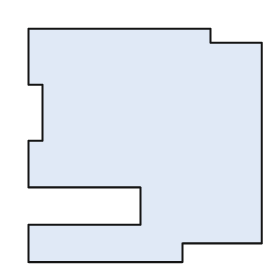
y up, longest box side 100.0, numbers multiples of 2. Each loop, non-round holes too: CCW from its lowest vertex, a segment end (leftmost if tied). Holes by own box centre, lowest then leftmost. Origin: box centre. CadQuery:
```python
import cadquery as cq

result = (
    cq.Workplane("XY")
    .moveTo(-50.0, -50.0)
    .lineTo(16.0, -50.0)
    .lineTo(16.0, -42.0)
    .lineTo(50.0, -42.0)
    .lineTo(50.0, 44.0)
    .lineTo(28.0, 44.0)
    .lineTo(28.0, 50.0)
    .lineTo(-50.0, 50.0)
    .lineTo(-50.0, 26.0)
    .lineTo(-44.0, 26.0)
    .lineTo(-44.0, 2.0)
    .lineTo(-50.0, 2.0)
    .lineTo(-50.0, -18.0)
    .lineTo(-2.0, -18.0)
    .lineTo(-2.0, -34.0)
    .lineTo(-50.0, -34.0)
    .close()
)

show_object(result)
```